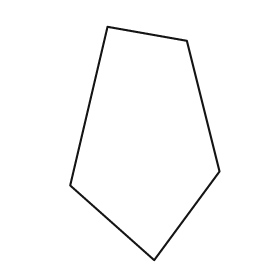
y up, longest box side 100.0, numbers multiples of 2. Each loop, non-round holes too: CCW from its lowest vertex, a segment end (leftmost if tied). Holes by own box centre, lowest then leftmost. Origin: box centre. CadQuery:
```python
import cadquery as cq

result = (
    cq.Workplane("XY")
    .moveTo(4.0, -50.0)
    .lineTo(32.0, -12.0)
    .lineTo(18.0, 44.0)
    .lineTo(-16.0, 50.0)
    .lineTo(-32.0, -18.0)
    .close()
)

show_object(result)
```